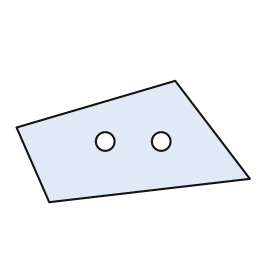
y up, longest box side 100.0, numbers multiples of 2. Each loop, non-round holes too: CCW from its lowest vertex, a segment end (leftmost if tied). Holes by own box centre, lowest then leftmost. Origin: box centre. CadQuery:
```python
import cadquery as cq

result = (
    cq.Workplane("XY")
    .moveTo(-36.0, -26.0)
    .lineTo(50.0, -16.0)
    .lineTo(18.0, 26.0)
    .lineTo(-50.0, 6.0)
    .close()
    .moveTo(-12.0, 0.0)
    .circle(4.0)
    .moveTo(12.0, 0.0)
    .circle(4.0)
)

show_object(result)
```